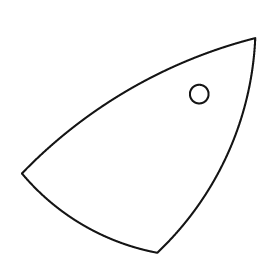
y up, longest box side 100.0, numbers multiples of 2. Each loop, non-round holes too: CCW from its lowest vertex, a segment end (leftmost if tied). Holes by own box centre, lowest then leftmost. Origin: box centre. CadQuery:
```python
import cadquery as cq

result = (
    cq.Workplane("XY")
    .moveTo(8.0, -46.0)
    .threePointArc((38.0, -4.0), (50.0, 46.0))
    .threePointArc((-4.0, 24.0), (-50.0, -12.0))
    .threePointArc((-24.0, -34.0), (8.0, -46.0))
    .close()
    .moveTo(26.0, 22.0)
    .circle(4.0)
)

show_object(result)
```